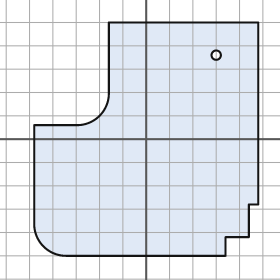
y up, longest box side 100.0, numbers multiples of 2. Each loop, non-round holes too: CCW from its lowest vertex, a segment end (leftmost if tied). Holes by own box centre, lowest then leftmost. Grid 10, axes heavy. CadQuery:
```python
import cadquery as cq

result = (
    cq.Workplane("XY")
    .moveTo(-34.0, -50.0)
    .lineTo(34.0, -50.0)
    .lineTo(34.0, -42.0)
    .lineTo(44.0, -42.0)
    .lineTo(44.0, -28.0)
    .lineTo(48.0, -28.0)
    .lineTo(48.0, 50.0)
    .lineTo(-16.0, 50.0)
    .lineTo(-16.0, 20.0)
    .threePointArc((-20.0, 10.0), (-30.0, 6.0))
    .lineTo(-48.0, 6.0)
    .lineTo(-48.0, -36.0)
    .threePointArc((-44.0, -46.0), (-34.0, -50.0))
    .close()
    .moveTo(30.0, 36.0)
    .circle(2.0)
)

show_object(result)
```